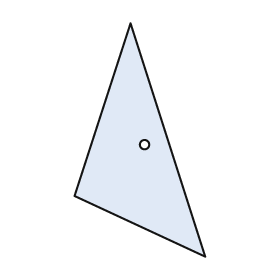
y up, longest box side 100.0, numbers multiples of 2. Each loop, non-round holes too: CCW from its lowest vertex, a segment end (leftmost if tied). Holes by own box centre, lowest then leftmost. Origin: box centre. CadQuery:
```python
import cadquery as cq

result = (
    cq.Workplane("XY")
    .moveTo(28.0, -50.0)
    .lineTo(-4.0, 50.0)
    .lineTo(-28.0, -24.0)
    .close()
    .moveTo(2.0, -2.0)
    .circle(2.0)
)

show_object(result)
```